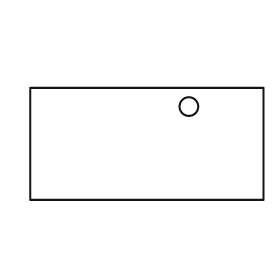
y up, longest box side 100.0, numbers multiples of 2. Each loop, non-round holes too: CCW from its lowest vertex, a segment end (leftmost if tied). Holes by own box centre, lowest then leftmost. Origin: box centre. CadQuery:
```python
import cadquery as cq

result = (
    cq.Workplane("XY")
    .moveTo(-50.0, -24.0)
    .lineTo(50.0, -24.0)
    .lineTo(50.0, 24.0)
    .lineTo(-50.0, 24.0)
    .close()
    .moveTo(18.0, 16.0)
    .circle(4.0)
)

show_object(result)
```